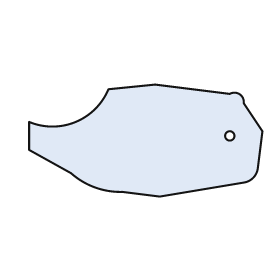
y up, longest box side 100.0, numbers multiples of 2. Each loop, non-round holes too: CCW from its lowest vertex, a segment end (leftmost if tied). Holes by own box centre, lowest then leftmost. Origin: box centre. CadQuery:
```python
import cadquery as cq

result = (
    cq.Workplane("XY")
    .moveTo(6.0, -24.0)
    .lineTo(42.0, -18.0)
    .threePointArc((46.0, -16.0), (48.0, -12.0))
    .lineTo(50.0, 4.0)
    .lineTo(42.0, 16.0)
    .threePointArc((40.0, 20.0), (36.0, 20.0))
    .lineTo(4.0, 24.0)
    .lineTo(-16.0, 22.0)
    .threePointArc((-30.0, 8.0), (-50.0, 8.0))
    .lineTo(-50.0, -4.0)
    .lineTo(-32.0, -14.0)
    .threePointArc((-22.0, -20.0), (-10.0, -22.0))
    .close()
    .moveTo(36.0, 2.0)
    .circle(2.0)
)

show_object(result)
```